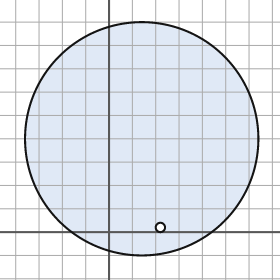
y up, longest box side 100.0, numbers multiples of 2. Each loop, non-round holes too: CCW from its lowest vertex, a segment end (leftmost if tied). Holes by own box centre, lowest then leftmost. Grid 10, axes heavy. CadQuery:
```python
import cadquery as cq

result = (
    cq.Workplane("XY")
    .moveTo(14.0, 40.0)
    .circle(50.0)
    .moveTo(22.0, 2.0)
    .circle(2.0)
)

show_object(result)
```